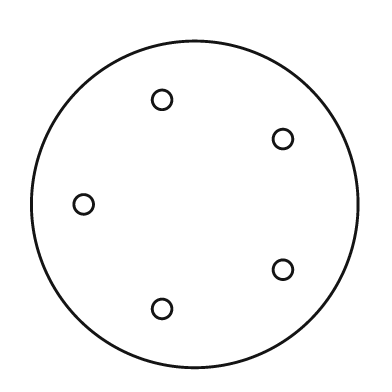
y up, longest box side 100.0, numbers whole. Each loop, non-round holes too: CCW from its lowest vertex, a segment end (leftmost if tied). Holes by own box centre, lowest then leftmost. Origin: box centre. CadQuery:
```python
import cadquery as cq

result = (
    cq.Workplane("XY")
    .moveTo(0.0, 0.0)
    .circle(50.0)
    .moveTo(-10.0, -32.0)
    .circle(3.0)
    .moveTo(27.0, -20.0)
    .circle(3.0)
    .moveTo(-34.0, 0.0)
    .circle(3.0)
    .moveTo(27.0, 20.0)
    .circle(3.0)
    .moveTo(-10.0, 32.0)
    .circle(3.0)
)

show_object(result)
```